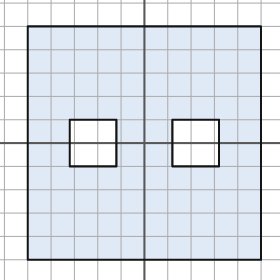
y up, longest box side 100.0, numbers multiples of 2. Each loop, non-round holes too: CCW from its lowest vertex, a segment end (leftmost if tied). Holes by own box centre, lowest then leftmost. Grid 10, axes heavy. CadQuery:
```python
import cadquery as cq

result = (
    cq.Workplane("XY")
    .moveTo(-50.0, -50.0)
    .lineTo(50.0, -50.0)
    .lineTo(50.0, 50.0)
    .lineTo(-50.0, 50.0)
    .close()
    .moveTo(-32.0, -10.0)
    .lineTo(-12.0, -10.0)
    .lineTo(-12.0, 10.0)
    .lineTo(-32.0, 10.0)
    .close()
    .moveTo(12.0, -10.0)
    .lineTo(32.0, -10.0)
    .lineTo(32.0, 10.0)
    .lineTo(12.0, 10.0)
    .close()
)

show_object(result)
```